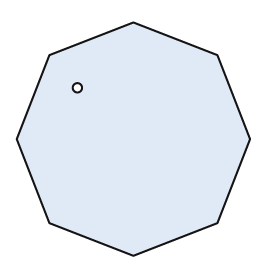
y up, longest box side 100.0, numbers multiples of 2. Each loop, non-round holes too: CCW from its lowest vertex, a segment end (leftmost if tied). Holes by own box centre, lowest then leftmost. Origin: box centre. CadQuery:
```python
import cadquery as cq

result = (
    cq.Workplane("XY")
    .moveTo(0.0, -50.0)
    .lineTo(36.0, -36.0)
    .lineTo(50.0, 0.0)
    .lineTo(36.0, 36.0)
    .lineTo(0.0, 50.0)
    .lineTo(-36.0, 36.0)
    .lineTo(-50.0, 0.0)
    .lineTo(-36.0, -36.0)
    .close()
    .moveTo(-24.0, 22.0)
    .circle(2.0)
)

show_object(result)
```